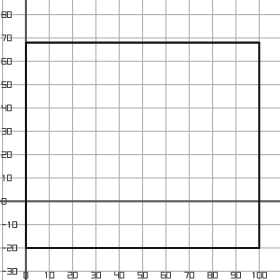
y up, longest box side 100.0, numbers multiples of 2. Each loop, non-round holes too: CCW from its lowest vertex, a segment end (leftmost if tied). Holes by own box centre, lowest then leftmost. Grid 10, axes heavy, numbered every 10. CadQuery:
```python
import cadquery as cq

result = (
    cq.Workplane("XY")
    .moveTo(0.0, -20.0)
    .lineTo(100.0, -20.0)
    .lineTo(100.0, 68.0)
    .lineTo(0.0, 68.0)
    .close()
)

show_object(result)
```